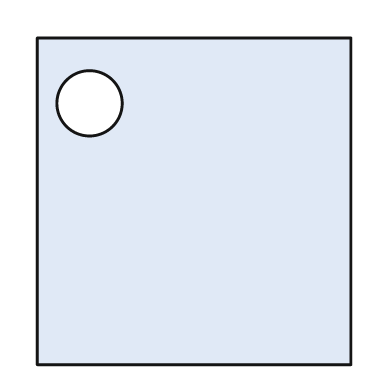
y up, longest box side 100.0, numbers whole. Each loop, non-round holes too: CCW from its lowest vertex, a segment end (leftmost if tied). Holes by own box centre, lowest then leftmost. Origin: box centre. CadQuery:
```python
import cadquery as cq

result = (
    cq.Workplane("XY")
    .moveTo(-48.0, -50.0)
    .lineTo(48.0, -50.0)
    .lineTo(48.0, 50.0)
    .lineTo(-48.0, 50.0)
    .close()
    .moveTo(-32.0, 30.0)
    .circle(10.0)
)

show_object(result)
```